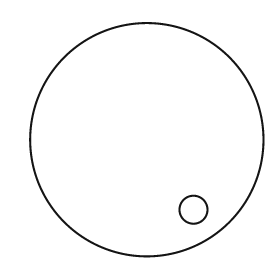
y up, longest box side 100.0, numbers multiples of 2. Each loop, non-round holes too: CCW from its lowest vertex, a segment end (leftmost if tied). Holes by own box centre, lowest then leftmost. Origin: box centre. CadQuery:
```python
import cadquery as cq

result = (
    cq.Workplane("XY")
    .moveTo(0.0, 0.0)
    .circle(50.0)
    .moveTo(20.0, -30.0)
    .circle(6.0)
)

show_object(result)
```